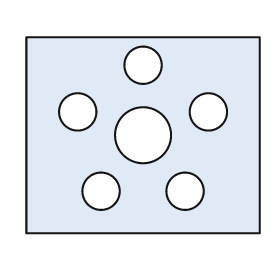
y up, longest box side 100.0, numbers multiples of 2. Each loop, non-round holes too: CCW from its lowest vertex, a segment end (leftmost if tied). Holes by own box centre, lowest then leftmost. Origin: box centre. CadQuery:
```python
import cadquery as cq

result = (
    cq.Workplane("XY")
    .moveTo(-50.0, -42.0)
    .lineTo(50.0, -42.0)
    .lineTo(50.0, 42.0)
    .lineTo(-50.0, 42.0)
    .close()
    .moveTo(-18.0, -24.0)
    .circle(8.0)
    .moveTo(18.0, -24.0)
    .circle(8.0)
    .moveTo(0.0, 0.0)
    .circle(12.0)
    .moveTo(-28.0, 10.0)
    .circle(8.0)
    .moveTo(28.0, 10.0)
    .circle(8.0)
    .moveTo(0.0, 30.0)
    .circle(8.0)
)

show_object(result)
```